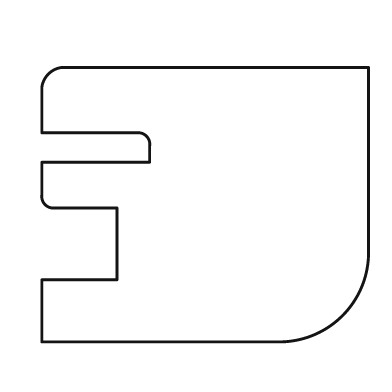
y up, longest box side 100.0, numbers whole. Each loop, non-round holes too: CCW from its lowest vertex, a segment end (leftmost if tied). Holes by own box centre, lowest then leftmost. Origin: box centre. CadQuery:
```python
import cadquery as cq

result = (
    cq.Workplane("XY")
    .moveTo(-50.0, -42.0)
    .lineTo(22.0, -42.0)
    .threePointArc((42.0, -34.0), (50.0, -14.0))
    .lineTo(50.0, 42.0)
    .lineTo(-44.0, 42.0)
    .threePointArc((-48.0, 40.0), (-50.0, 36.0))
    .lineTo(-50.0, 22.0)
    .lineTo(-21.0, 22.0)
    .threePointArc((-18.0, 21.0), (-17.0, 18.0))
    .lineTo(-17.0, 13.0)
    .lineTo(-50.0, 13.0)
    .lineTo(-50.0, 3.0)
    .threePointArc((-49.0, 0.0), (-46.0, -1.0))
    .lineTo(-27.0, -1.0)
    .lineTo(-27.0, -23.0)
    .lineTo(-50.0, -23.0)
    .close()
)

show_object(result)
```